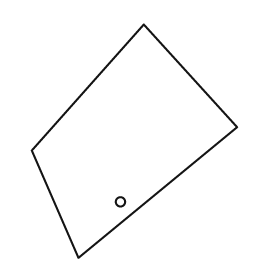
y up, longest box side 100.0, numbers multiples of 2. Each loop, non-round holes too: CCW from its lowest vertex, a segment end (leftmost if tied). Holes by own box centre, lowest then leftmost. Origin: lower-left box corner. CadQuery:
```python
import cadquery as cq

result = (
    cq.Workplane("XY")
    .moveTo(20.0, 0.0)
    .lineTo(88.0, 56.0)
    .lineTo(48.0, 100.0)
    .lineTo(0.0, 46.0)
    .close()
    .moveTo(38.0, 24.0)
    .circle(2.0)
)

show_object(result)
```